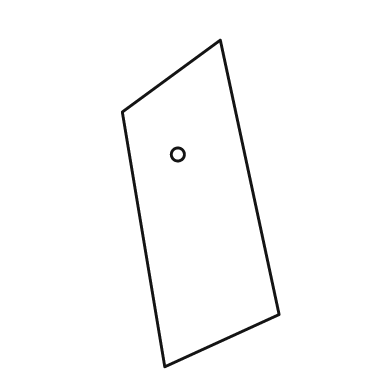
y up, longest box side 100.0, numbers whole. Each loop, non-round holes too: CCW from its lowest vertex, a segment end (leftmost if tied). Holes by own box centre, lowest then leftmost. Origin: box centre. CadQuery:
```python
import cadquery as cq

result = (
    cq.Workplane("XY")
    .moveTo(-11.0, -50.0)
    .lineTo(24.0, -34.0)
    .lineTo(6.0, 50.0)
    .lineTo(-24.0, 28.0)
    .close()
    .moveTo(-7.0, 15.0)
    .circle(2.0)
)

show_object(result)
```